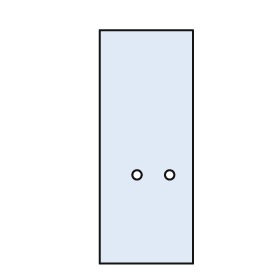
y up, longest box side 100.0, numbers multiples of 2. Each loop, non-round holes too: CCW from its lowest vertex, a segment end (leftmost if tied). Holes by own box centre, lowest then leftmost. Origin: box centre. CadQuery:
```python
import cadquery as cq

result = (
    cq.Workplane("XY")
    .moveTo(-20.0, -50.0)
    .lineTo(20.0, -50.0)
    .lineTo(20.0, 50.0)
    .lineTo(-20.0, 50.0)
    .close()
    .moveTo(-4.0, -12.0)
    .circle(2.0)
    .moveTo(10.0, -12.0)
    .circle(2.0)
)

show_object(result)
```